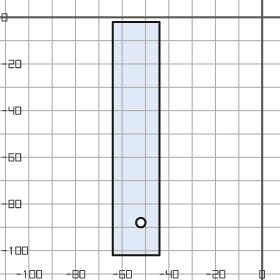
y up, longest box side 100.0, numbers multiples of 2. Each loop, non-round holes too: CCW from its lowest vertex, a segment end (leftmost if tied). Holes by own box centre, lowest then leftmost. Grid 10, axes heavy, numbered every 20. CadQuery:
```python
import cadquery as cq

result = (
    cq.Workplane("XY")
    .moveTo(-64.0, -102.0)
    .lineTo(-44.0, -102.0)
    .lineTo(-44.0, -2.0)
    .lineTo(-64.0, -2.0)
    .close()
    .moveTo(-52.0, -88.0)
    .circle(2.0)
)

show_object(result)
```